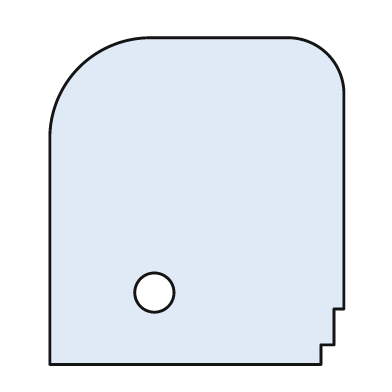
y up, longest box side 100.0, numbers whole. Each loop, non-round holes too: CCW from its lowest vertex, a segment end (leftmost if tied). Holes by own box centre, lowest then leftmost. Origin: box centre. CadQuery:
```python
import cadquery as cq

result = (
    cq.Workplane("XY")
    .moveTo(-45.0, -50.0)
    .lineTo(38.0, -50.0)
    .lineTo(38.0, -44.0)
    .lineTo(42.0, -44.0)
    .lineTo(42.0, -33.0)
    .lineTo(45.0, -33.0)
    .lineTo(45.0, 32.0)
    .threePointArc((40.0, 45.0), (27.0, 50.0))
    .lineTo(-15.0, 50.0)
    .threePointArc((-36.0, 41.0), (-45.0, 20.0))
    .close()
    .moveTo(-13.0, -28.0)
    .circle(6.0)
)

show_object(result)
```